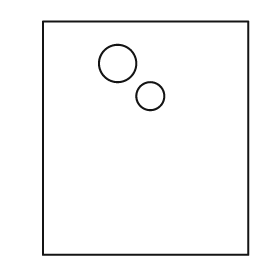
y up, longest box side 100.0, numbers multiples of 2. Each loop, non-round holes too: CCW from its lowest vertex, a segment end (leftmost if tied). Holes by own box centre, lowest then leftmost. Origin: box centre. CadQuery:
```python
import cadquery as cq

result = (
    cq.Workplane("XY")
    .moveTo(-44.0, -50.0)
    .lineTo(44.0, -50.0)
    .lineTo(44.0, 50.0)
    .lineTo(-44.0, 50.0)
    .close()
    .moveTo(2.0, 18.0)
    .circle(6.0)
    .moveTo(-12.0, 32.0)
    .circle(8.0)
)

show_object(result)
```